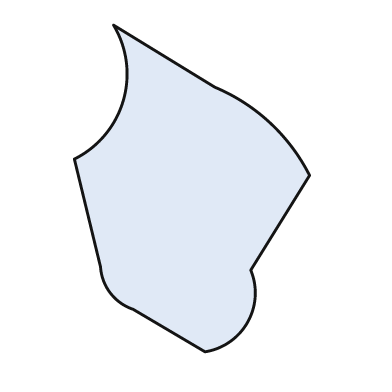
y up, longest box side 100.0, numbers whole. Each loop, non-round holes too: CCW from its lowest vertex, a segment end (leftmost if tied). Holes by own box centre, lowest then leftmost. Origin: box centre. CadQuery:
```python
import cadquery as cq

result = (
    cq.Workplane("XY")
    .moveTo(4.0, -50.0)
    .threePointArc((17.0, -41.0), (18.0, -25.0))
    .lineTo(36.0, 4.0)
    .threePointArc((24.0, 20.0), (7.0, 31.0))
    .lineTo(-24.0, 50.0)
    .threePointArc((-21.0, 27.0), (-36.0, 9.0))
    .lineTo(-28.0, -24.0)
    .threePointArc((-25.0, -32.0), (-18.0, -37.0))
    .close()
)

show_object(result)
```